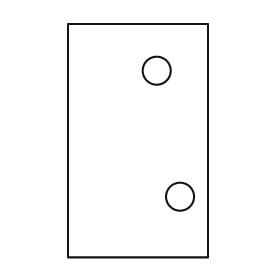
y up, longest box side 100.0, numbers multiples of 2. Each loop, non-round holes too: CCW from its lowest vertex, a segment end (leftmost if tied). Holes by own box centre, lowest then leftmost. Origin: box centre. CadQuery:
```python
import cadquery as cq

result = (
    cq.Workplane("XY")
    .moveTo(-30.0, -50.0)
    .lineTo(30.0, -50.0)
    .lineTo(30.0, 50.0)
    .lineTo(-30.0, 50.0)
    .close()
    .moveTo(18.0, -24.0)
    .circle(6.0)
    .moveTo(8.0, 30.0)
    .circle(6.0)
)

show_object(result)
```